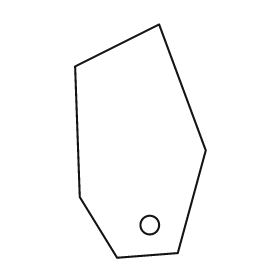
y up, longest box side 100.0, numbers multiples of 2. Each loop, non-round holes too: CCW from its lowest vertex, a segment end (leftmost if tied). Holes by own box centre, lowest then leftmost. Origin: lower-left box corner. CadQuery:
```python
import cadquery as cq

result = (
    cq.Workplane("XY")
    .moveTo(18.0, 0.0)
    .lineTo(44.0, 2.0)
    .lineTo(56.0, 46.0)
    .lineTo(36.0, 100.0)
    .lineTo(0.0, 82.0)
    .lineTo(2.0, 26.0)
    .close()
    .moveTo(32.0, 14.0)
    .circle(4.0)
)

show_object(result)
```